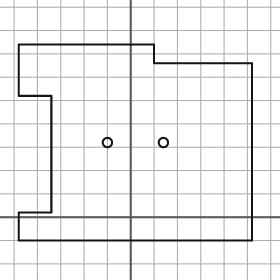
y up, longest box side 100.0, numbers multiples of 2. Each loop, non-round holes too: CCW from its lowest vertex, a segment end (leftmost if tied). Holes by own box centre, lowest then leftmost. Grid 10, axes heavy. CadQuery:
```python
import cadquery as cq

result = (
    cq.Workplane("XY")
    .moveTo(-48.0, -10.0)
    .lineTo(52.0, -10.0)
    .lineTo(52.0, 66.0)
    .lineTo(10.0, 66.0)
    .lineTo(10.0, 74.0)
    .lineTo(-48.0, 74.0)
    .lineTo(-48.0, 52.0)
    .lineTo(-34.0, 52.0)
    .lineTo(-34.0, 2.0)
    .lineTo(-48.0, 2.0)
    .close()
    .moveTo(-10.0, 32.0)
    .circle(2.0)
    .moveTo(14.0, 32.0)
    .circle(2.0)
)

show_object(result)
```